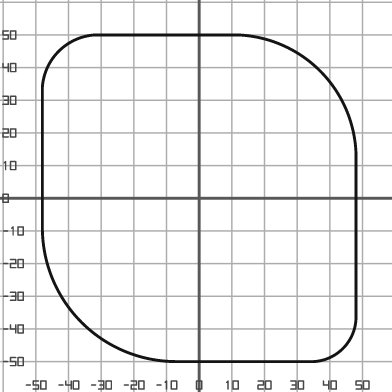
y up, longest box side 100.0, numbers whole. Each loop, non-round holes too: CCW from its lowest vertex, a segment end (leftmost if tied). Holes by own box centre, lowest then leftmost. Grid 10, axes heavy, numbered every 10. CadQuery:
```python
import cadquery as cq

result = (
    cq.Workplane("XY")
    .moveTo(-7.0, -50.0)
    .lineTo(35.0, -50.0)
    .threePointArc((44.0, -46.0), (48.0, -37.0))
    .lineTo(48.0, 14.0)
    .threePointArc((37.0, 39.0), (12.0, 50.0))
    .lineTo(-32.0, 50.0)
    .threePointArc((-43.0, 45.0), (-48.0, 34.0))
    .lineTo(-48.0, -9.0)
    .threePointArc((-36.0, -38.0), (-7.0, -50.0))
    .close()
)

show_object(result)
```